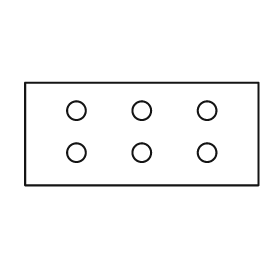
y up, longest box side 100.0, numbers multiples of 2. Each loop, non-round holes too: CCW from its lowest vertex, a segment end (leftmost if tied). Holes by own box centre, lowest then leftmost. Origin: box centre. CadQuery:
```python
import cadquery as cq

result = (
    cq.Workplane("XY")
    .moveTo(-50.0, -22.0)
    .lineTo(50.0, -22.0)
    .lineTo(50.0, 22.0)
    .lineTo(-50.0, 22.0)
    .close()
    .moveTo(-28.0, -8.0)
    .circle(4.0)
    .moveTo(0.0, -8.0)
    .circle(4.0)
    .moveTo(28.0, -8.0)
    .circle(4.0)
    .moveTo(-28.0, 10.0)
    .circle(4.0)
    .moveTo(0.0, 10.0)
    .circle(4.0)
    .moveTo(28.0, 10.0)
    .circle(4.0)
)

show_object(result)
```